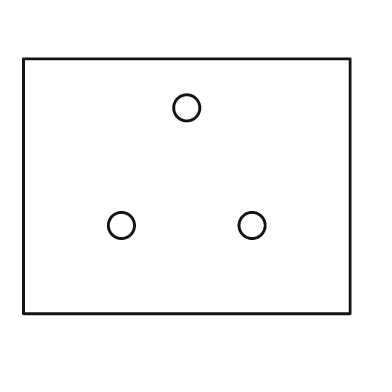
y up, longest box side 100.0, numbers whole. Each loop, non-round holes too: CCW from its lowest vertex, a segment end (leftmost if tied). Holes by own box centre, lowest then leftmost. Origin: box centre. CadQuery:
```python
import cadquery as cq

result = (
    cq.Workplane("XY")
    .moveTo(-50.0, -39.0)
    .lineTo(50.0, -39.0)
    .lineTo(50.0, 39.0)
    .lineTo(-50.0, 39.0)
    .close()
    .moveTo(-20.0, -12.0)
    .circle(4.0)
    .moveTo(20.0, -12.0)
    .circle(4.0)
    .moveTo(0.0, 24.0)
    .circle(4.0)
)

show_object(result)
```